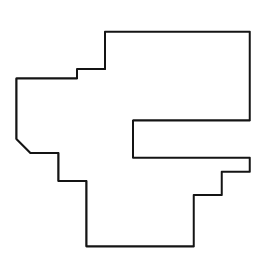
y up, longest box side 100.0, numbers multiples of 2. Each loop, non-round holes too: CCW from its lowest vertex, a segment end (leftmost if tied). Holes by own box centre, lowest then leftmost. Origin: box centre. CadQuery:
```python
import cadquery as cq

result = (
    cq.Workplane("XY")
    .moveTo(-20.0, -46.0)
    .lineTo(26.0, -46.0)
    .lineTo(26.0, -24.0)
    .lineTo(38.0, -24.0)
    .lineTo(38.0, -14.0)
    .lineTo(50.0, -14.0)
    .lineTo(50.0, -8.0)
    .lineTo(0.0, -8.0)
    .lineTo(0.0, 8.0)
    .lineTo(50.0, 8.0)
    .lineTo(50.0, 46.0)
    .lineTo(-12.0, 46.0)
    .lineTo(-12.0, 30.0)
    .lineTo(-24.0, 30.0)
    .lineTo(-24.0, 26.0)
    .lineTo(-50.0, 26.0)
    .lineTo(-50.0, 0.0)
    .lineTo(-44.0, -6.0)
    .lineTo(-32.0, -6.0)
    .lineTo(-32.0, -18.0)
    .lineTo(-20.0, -18.0)
    .close()
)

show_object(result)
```